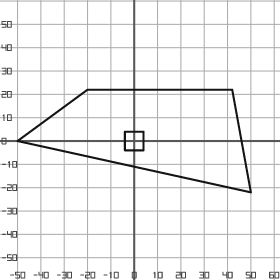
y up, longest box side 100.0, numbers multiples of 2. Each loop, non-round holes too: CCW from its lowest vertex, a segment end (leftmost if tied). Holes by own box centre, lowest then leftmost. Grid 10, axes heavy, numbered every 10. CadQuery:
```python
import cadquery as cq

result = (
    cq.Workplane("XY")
    .moveTo(50.0, -22.0)
    .lineTo(42.0, 22.0)
    .lineTo(-20.0, 22.0)
    .lineTo(-50.0, 0.0)
    .close()
    .moveTo(-4.0, -4.0)
    .lineTo(4.0, -4.0)
    .lineTo(4.0, 4.0)
    .lineTo(-4.0, 4.0)
    .close()
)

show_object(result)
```